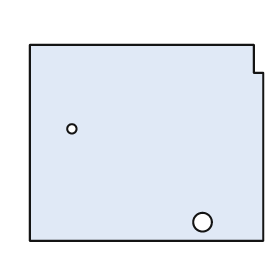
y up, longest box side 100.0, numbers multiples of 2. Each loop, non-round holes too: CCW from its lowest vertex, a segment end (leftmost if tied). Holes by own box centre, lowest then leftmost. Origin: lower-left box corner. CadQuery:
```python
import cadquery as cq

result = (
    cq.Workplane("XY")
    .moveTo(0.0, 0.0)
    .lineTo(100.0, 0.0)
    .lineTo(100.0, 72.0)
    .lineTo(96.0, 72.0)
    .lineTo(96.0, 84.0)
    .lineTo(0.0, 84.0)
    .close()
    .moveTo(74.0, 8.0)
    .circle(4.0)
    .moveTo(18.0, 48.0)
    .circle(2.0)
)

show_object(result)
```